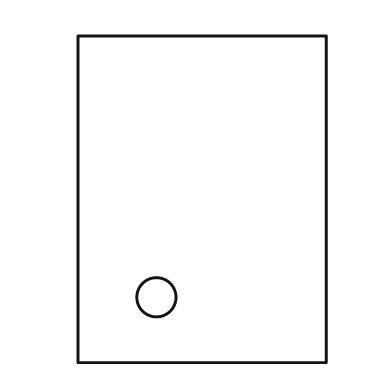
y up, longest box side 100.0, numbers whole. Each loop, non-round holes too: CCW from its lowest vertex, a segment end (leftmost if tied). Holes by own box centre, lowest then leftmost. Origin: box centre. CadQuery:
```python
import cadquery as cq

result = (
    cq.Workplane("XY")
    .moveTo(-38.0, -50.0)
    .lineTo(38.0, -50.0)
    .lineTo(38.0, 50.0)
    .lineTo(-38.0, 50.0)
    .close()
    .moveTo(-14.0, -30.0)
    .circle(6.0)
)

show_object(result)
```